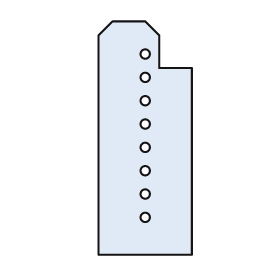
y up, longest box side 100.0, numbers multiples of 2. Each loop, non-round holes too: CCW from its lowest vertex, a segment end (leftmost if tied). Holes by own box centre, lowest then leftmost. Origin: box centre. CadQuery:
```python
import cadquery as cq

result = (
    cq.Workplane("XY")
    .moveTo(-20.0, -50.0)
    .lineTo(20.0, -50.0)
    .lineTo(20.0, 30.0)
    .lineTo(6.0, 30.0)
    .lineTo(6.0, 44.0)
    .lineTo(0.0, 50.0)
    .lineTo(-14.0, 50.0)
    .lineTo(-20.0, 44.0)
    .close()
    .moveTo(0.0, -34.0)
    .circle(2.0)
    .moveTo(0.0, -24.0)
    .circle(2.0)
    .moveTo(0.0, -14.0)
    .circle(2.0)
    .moveTo(0.0, -4.0)
    .circle(2.0)
    .moveTo(0.0, 6.0)
    .circle(2.0)
    .moveTo(0.0, 16.0)
    .circle(2.0)
    .moveTo(0.0, 26.0)
    .circle(2.0)
    .moveTo(0.0, 36.0)
    .circle(2.0)
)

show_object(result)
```